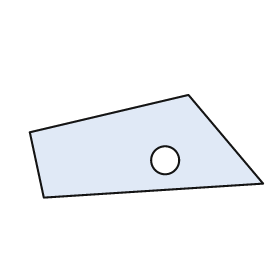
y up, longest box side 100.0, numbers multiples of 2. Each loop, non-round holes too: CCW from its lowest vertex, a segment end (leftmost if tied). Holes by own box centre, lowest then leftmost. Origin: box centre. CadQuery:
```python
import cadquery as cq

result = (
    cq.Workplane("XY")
    .moveTo(-44.0, -22.0)
    .lineTo(50.0, -16.0)
    .lineTo(18.0, 22.0)
    .lineTo(-50.0, 6.0)
    .close()
    .moveTo(8.0, -6.0)
    .circle(6.0)
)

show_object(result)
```